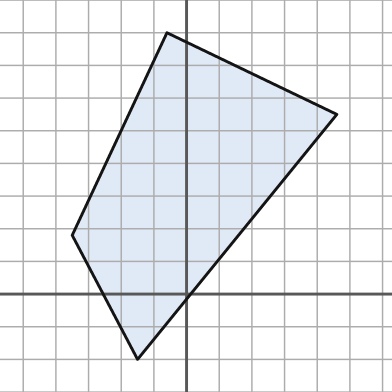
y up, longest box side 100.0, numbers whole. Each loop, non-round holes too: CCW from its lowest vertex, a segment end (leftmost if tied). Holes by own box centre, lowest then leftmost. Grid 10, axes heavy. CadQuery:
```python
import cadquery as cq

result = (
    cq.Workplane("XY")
    .moveTo(-15.0, -20.0)
    .lineTo(46.0, 55.0)
    .lineTo(-6.0, 80.0)
    .lineTo(-35.0, 18.0)
    .close()
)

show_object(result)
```